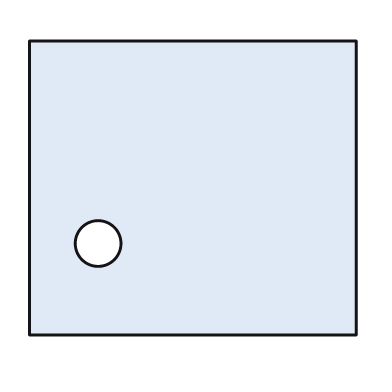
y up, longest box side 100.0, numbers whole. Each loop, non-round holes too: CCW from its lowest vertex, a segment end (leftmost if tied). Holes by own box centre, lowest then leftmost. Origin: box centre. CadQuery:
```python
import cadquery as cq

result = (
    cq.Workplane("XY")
    .moveTo(-50.0, -45.0)
    .lineTo(50.0, -45.0)
    .lineTo(50.0, 45.0)
    .lineTo(-50.0, 45.0)
    .close()
    .moveTo(-29.0, -17.0)
    .circle(7.0)
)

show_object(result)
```